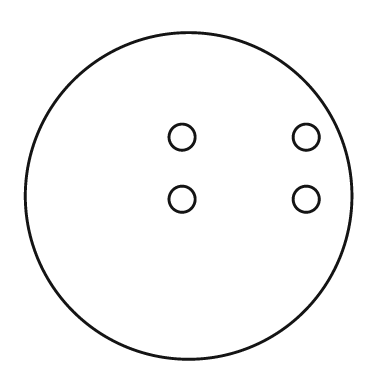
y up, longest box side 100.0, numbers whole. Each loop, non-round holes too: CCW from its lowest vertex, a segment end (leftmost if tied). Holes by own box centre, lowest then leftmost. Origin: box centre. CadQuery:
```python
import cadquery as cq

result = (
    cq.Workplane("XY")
    .moveTo(0.0, 0.0)
    .circle(50.0)
    .moveTo(-2.0, -1.0)
    .circle(4.0)
    .moveTo(36.0, -1.0)
    .circle(4.0)
    .moveTo(-2.0, 18.0)
    .circle(4.0)
    .moveTo(36.0, 18.0)
    .circle(4.0)
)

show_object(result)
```